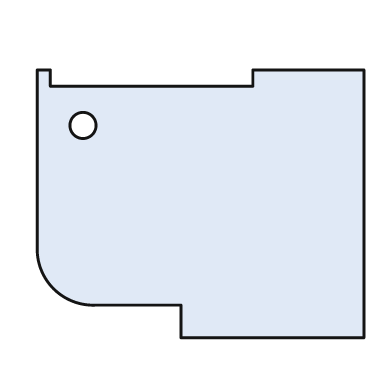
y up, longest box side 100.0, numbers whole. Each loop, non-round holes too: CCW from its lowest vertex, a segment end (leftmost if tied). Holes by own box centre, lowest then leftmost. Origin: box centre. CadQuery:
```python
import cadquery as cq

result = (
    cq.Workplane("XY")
    .moveTo(-6.0, -41.0)
    .lineTo(50.0, -41.0)
    .lineTo(50.0, 41.0)
    .lineTo(16.0, 41.0)
    .lineTo(16.0, 36.0)
    .lineTo(-46.0, 36.0)
    .lineTo(-46.0, 41.0)
    .lineTo(-50.0, 41.0)
    .lineTo(-50.0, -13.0)
    .threePointArc((-45.0, -26.0), (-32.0, -31.0))
    .lineTo(-6.0, -31.0)
    .close()
    .moveTo(-36.0, 24.0)
    .circle(4.0)
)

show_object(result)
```